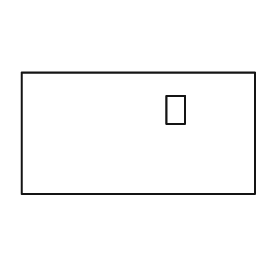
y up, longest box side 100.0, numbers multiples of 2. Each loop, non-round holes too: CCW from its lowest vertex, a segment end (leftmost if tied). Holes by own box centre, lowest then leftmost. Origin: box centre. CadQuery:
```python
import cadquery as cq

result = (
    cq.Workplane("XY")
    .moveTo(-50.0, -26.0)
    .lineTo(50.0, -26.0)
    .lineTo(50.0, 26.0)
    .lineTo(-50.0, 26.0)
    .close()
    .moveTo(12.0, 4.0)
    .lineTo(20.0, 4.0)
    .lineTo(20.0, 16.0)
    .lineTo(12.0, 16.0)
    .close()
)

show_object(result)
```